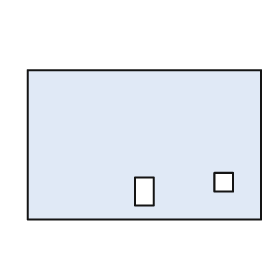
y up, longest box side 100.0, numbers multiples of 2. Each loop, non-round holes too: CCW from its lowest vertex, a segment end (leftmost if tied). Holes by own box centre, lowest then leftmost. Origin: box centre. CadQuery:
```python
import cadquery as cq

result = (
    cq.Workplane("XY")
    .moveTo(-50.0, -32.0)
    .lineTo(50.0, -32.0)
    .lineTo(50.0, 32.0)
    .lineTo(-50.0, 32.0)
    .close()
    .moveTo(-4.0, -26.0)
    .lineTo(4.0, -26.0)
    .lineTo(4.0, -14.0)
    .lineTo(-4.0, -14.0)
    .close()
    .moveTo(30.0, -20.0)
    .lineTo(38.0, -20.0)
    .lineTo(38.0, -12.0)
    .lineTo(30.0, -12.0)
    .close()
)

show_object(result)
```